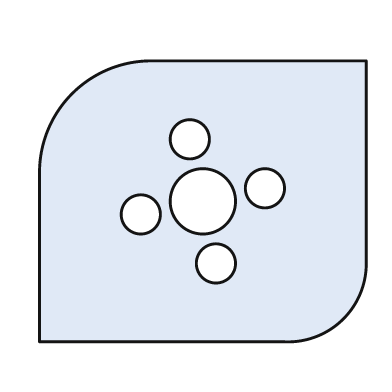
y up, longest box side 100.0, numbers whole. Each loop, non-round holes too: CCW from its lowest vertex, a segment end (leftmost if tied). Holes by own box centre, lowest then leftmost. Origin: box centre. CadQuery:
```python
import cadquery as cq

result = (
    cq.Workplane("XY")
    .moveTo(-50.0, -43.0)
    .lineTo(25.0, -43.0)
    .threePointArc((43.0, -36.0), (50.0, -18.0))
    .lineTo(50.0, 43.0)
    .lineTo(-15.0, 43.0)
    .threePointArc((-40.0, 33.0), (-50.0, 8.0))
    .close()
    .moveTo(4.0, -19.0)
    .circle(6.0)
    .moveTo(-19.0, -4.0)
    .circle(6.0)
    .moveTo(0.0, 0.0)
    .circle(10.0)
    .moveTo(19.0, 4.0)
    .circle(6.0)
    .moveTo(-4.0, 19.0)
    .circle(6.0)
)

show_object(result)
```